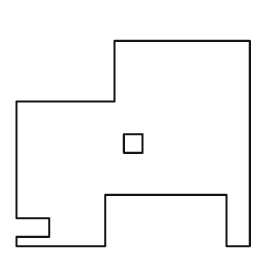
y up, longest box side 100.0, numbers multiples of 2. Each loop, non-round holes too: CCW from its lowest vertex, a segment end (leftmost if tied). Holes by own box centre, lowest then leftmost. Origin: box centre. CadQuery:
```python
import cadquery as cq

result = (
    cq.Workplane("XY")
    .moveTo(-50.0, -44.0)
    .lineTo(-12.0, -44.0)
    .lineTo(-12.0, -22.0)
    .lineTo(40.0, -22.0)
    .lineTo(40.0, -44.0)
    .lineTo(50.0, -44.0)
    .lineTo(50.0, 44.0)
    .lineTo(-8.0, 44.0)
    .lineTo(-8.0, 18.0)
    .lineTo(-50.0, 18.0)
    .lineTo(-50.0, -32.0)
    .lineTo(-36.0, -32.0)
    .lineTo(-36.0, -40.0)
    .lineTo(-50.0, -40.0)
    .close()
    .moveTo(-4.0, -4.0)
    .lineTo(4.0, -4.0)
    .lineTo(4.0, 4.0)
    .lineTo(-4.0, 4.0)
    .close()
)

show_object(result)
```